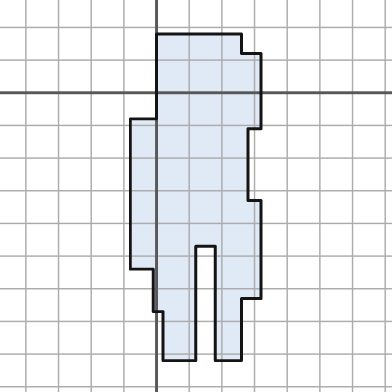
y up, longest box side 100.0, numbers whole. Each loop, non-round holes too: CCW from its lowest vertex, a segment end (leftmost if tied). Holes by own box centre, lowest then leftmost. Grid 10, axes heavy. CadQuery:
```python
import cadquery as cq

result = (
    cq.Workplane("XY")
    .moveTo(2.0, -82.0)
    .lineTo(12.0, -82.0)
    .lineTo(12.0, -47.0)
    .lineTo(18.0, -47.0)
    .lineTo(18.0, -82.0)
    .lineTo(26.0, -82.0)
    .lineTo(26.0, -63.0)
    .lineTo(32.0, -63.0)
    .lineTo(32.0, -33.0)
    .lineTo(28.0, -33.0)
    .lineTo(28.0, -11.0)
    .lineTo(32.0, -11.0)
    .lineTo(32.0, 12.0)
    .lineTo(26.0, 12.0)
    .lineTo(26.0, 18.0)
    .lineTo(0.0, 18.0)
    .lineTo(0.0, -8.0)
    .lineTo(-8.0, -8.0)
    .lineTo(-8.0, -54.0)
    .lineTo(-1.0, -54.0)
    .lineTo(-1.0, -67.0)
    .lineTo(2.0, -67.0)
    .close()
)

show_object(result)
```